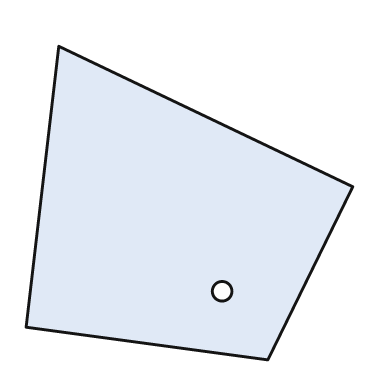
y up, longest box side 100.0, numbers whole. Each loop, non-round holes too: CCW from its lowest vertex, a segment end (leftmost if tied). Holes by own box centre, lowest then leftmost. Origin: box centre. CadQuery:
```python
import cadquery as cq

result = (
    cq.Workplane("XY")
    .moveTo(24.0, -48.0)
    .lineTo(50.0, 5.0)
    .lineTo(-40.0, 48.0)
    .lineTo(-50.0, -38.0)
    .close()
    .moveTo(10.0, -27.0)
    .circle(3.0)
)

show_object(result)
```